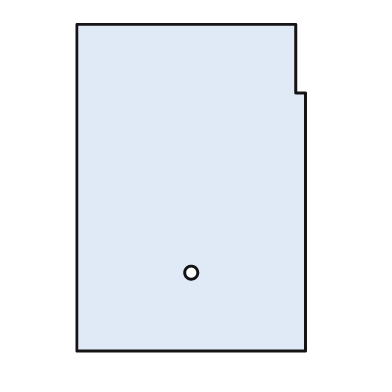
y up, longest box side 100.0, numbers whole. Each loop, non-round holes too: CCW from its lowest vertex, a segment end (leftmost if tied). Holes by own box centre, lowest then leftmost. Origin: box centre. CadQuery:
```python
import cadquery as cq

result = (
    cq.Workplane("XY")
    .moveTo(-35.0, -50.0)
    .lineTo(35.0, -50.0)
    .lineTo(35.0, 29.0)
    .lineTo(32.0, 29.0)
    .lineTo(32.0, 50.0)
    .lineTo(-35.0, 50.0)
    .close()
    .moveTo(0.0, -26.0)
    .circle(2.0)
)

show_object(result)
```